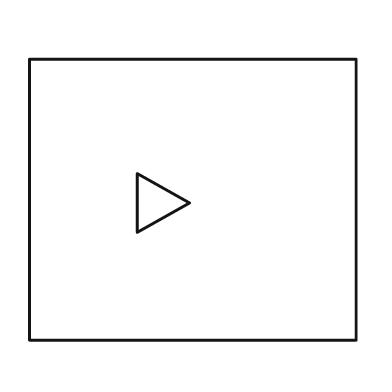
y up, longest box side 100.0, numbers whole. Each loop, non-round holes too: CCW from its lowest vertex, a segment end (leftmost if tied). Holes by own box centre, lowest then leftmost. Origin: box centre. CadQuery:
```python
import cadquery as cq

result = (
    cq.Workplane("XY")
    .moveTo(-50.0, -43.0)
    .lineTo(50.0, -43.0)
    .lineTo(50.0, 43.0)
    .lineTo(-50.0, 43.0)
    .close()
    .moveTo(-17.0, -10.0)
    .lineTo(-1.0, -1.0)
    .lineTo(-17.0, 8.0)
    .close()
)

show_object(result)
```